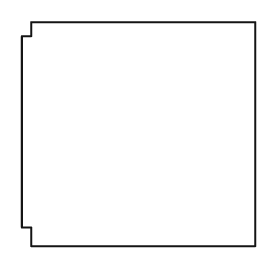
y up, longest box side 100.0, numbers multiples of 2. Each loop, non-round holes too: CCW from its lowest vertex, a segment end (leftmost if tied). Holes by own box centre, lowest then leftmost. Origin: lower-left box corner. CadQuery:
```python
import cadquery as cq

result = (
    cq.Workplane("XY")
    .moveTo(4.0, 0.0)
    .lineTo(100.0, 0.0)
    .lineTo(100.0, 96.0)
    .lineTo(4.0, 96.0)
    .lineTo(4.0, 90.0)
    .lineTo(0.0, 90.0)
    .lineTo(0.0, 8.0)
    .lineTo(4.0, 8.0)
    .close()
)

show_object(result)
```